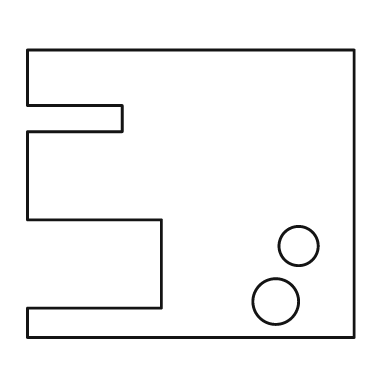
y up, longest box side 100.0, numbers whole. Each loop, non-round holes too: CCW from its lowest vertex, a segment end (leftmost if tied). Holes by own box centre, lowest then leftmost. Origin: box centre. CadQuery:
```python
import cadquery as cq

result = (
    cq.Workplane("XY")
    .moveTo(-50.0, -44.0)
    .lineTo(50.0, -44.0)
    .lineTo(50.0, 44.0)
    .lineTo(-50.0, 44.0)
    .lineTo(-50.0, 27.0)
    .lineTo(-21.0, 27.0)
    .lineTo(-21.0, 19.0)
    .lineTo(-50.0, 19.0)
    .lineTo(-50.0, -8.0)
    .lineTo(-9.0, -8.0)
    .lineTo(-9.0, -35.0)
    .lineTo(-50.0, -35.0)
    .close()
    .moveTo(26.0, -33.0)
    .circle(7.0)
    .moveTo(33.0, -16.0)
    .circle(6.0)
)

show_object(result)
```